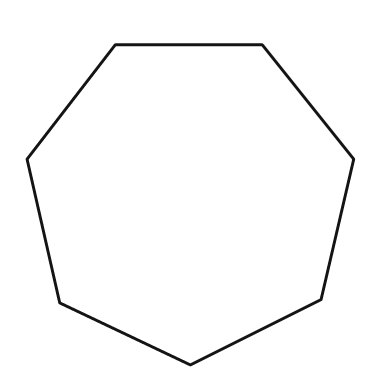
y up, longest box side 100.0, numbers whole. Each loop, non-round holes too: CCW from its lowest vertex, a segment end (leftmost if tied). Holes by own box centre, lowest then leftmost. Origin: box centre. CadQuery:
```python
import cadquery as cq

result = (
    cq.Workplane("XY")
    .moveTo(0.0, -49.0)
    .lineTo(40.0, -29.0)
    .lineTo(50.0, 14.0)
    .lineTo(22.0, 49.0)
    .lineTo(-23.0, 49.0)
    .lineTo(-50.0, 14.0)
    .lineTo(-40.0, -30.0)
    .close()
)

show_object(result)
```